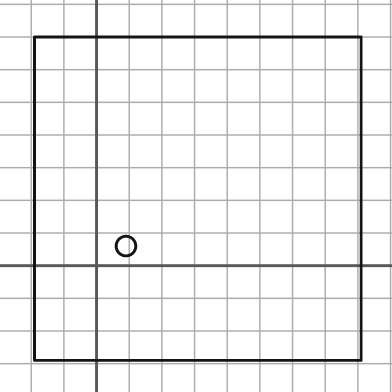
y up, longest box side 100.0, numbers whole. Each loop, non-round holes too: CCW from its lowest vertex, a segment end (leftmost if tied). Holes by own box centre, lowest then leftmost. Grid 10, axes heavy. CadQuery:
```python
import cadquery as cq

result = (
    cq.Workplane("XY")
    .moveTo(-19.0, -29.0)
    .lineTo(81.0, -29.0)
    .lineTo(81.0, 70.0)
    .lineTo(-19.0, 70.0)
    .close()
    .moveTo(9.0, 6.0)
    .circle(3.0)
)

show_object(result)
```